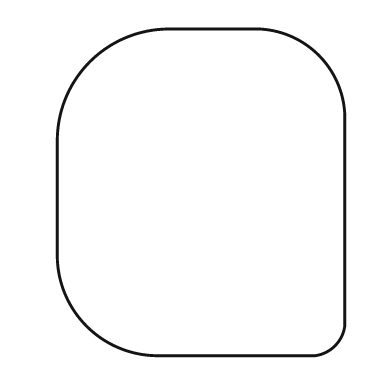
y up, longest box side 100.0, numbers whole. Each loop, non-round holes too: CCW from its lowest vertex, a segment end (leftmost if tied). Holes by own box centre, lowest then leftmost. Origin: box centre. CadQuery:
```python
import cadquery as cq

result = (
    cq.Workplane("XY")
    .moveTo(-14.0, -50.0)
    .lineTo(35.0, -50.0)
    .threePointArc((41.0, -47.0), (44.0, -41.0))
    .lineTo(44.0, 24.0)
    .threePointArc((36.0, 42.0), (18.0, 50.0))
    .lineTo(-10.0, 50.0)
    .threePointArc((-34.0, 40.0), (-44.0, 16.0))
    .lineTo(-44.0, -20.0)
    .threePointArc((-35.0, -41.0), (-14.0, -50.0))
    .close()
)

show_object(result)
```